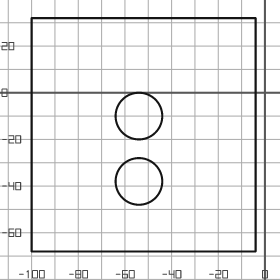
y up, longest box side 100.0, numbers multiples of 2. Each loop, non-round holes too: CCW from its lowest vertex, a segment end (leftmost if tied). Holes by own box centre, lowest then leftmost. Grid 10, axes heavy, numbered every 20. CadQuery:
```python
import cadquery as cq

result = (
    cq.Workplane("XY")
    .moveTo(-100.0, -68.0)
    .lineTo(-4.0, -68.0)
    .lineTo(-4.0, 32.0)
    .lineTo(-100.0, 32.0)
    .close()
    .moveTo(-54.0, -38.0)
    .circle(10.0)
    .moveTo(-54.0, -10.0)
    .circle(10.0)
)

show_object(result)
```